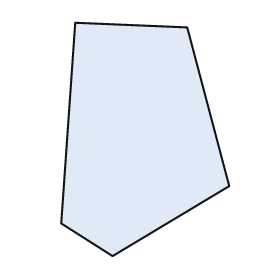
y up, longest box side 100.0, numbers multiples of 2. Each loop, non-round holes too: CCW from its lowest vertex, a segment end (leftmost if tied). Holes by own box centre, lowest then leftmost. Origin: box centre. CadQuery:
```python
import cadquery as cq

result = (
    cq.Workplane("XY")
    .moveTo(-14.0, -50.0)
    .lineTo(36.0, -20.0)
    .lineTo(18.0, 48.0)
    .lineTo(-30.0, 50.0)
    .lineTo(-36.0, -36.0)
    .close()
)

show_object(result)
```